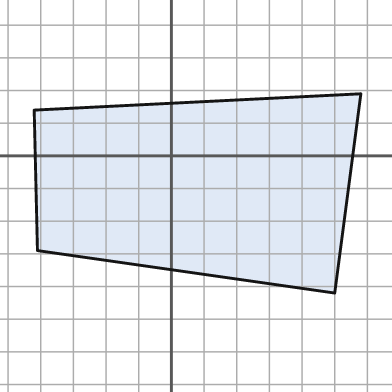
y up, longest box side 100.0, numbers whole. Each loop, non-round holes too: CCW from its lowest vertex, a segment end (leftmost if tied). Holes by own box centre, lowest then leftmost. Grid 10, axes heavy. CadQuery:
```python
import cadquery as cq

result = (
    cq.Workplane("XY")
    .moveTo(50.0, -42.0)
    .lineTo(58.0, 19.0)
    .lineTo(-42.0, 14.0)
    .lineTo(-41.0, -29.0)
    .close()
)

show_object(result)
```